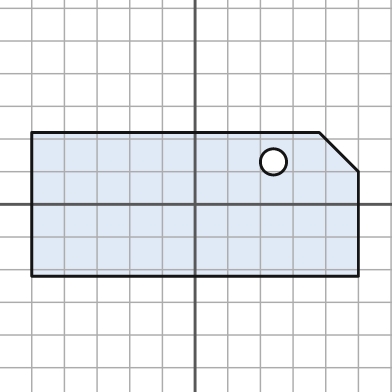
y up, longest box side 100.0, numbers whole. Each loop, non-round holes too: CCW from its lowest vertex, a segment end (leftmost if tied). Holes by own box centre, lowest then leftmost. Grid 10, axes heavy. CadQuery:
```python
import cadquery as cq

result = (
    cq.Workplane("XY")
    .moveTo(-50.0, -22.0)
    .lineTo(50.0, -22.0)
    .lineTo(50.0, 10.0)
    .lineTo(38.0, 22.0)
    .lineTo(-50.0, 22.0)
    .close()
    .moveTo(24.0, 13.0)
    .circle(4.0)
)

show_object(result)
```